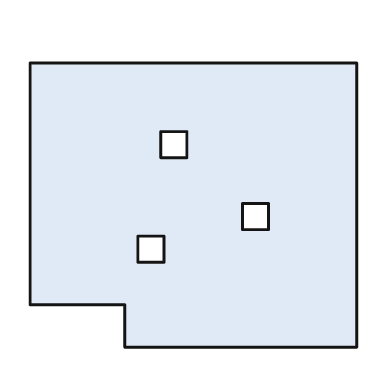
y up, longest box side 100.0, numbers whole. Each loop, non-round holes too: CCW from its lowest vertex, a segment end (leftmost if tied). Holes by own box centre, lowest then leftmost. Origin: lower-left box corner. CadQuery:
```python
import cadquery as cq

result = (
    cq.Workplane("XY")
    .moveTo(29.0, 0.0)
    .lineTo(100.0, 0.0)
    .lineTo(100.0, 87.0)
    .lineTo(0.0, 87.0)
    .lineTo(0.0, 13.0)
    .lineTo(29.0, 13.0)
    .close()
    .moveTo(33.0, 26.0)
    .lineTo(41.0, 26.0)
    .lineTo(41.0, 34.0)
    .lineTo(33.0, 34.0)
    .close()
    .moveTo(65.0, 36.0)
    .lineTo(73.0, 36.0)
    .lineTo(73.0, 44.0)
    .lineTo(65.0, 44.0)
    .close()
    .moveTo(40.0, 58.0)
    .lineTo(48.0, 58.0)
    .lineTo(48.0, 66.0)
    .lineTo(40.0, 66.0)
    .close()
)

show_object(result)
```